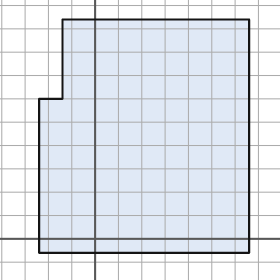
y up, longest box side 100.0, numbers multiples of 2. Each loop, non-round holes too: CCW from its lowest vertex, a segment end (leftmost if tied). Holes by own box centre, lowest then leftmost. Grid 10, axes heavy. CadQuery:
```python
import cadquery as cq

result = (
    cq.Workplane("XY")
    .moveTo(-24.0, -6.0)
    .lineTo(66.0, -6.0)
    .lineTo(66.0, 94.0)
    .lineTo(-14.0, 94.0)
    .lineTo(-14.0, 60.0)
    .lineTo(-24.0, 60.0)
    .close()
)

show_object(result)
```